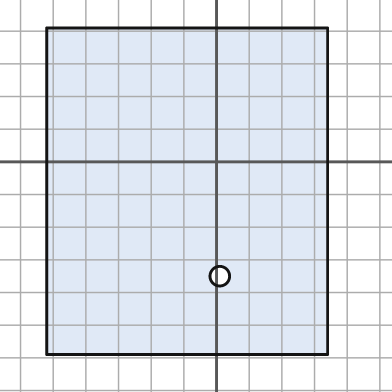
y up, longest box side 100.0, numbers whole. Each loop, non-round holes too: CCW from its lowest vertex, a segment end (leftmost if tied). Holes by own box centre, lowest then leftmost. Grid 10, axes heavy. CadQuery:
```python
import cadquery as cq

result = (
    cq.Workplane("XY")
    .moveTo(-52.0, -59.0)
    .lineTo(34.0, -59.0)
    .lineTo(34.0, 41.0)
    .lineTo(-52.0, 41.0)
    .close()
    .moveTo(1.0, -35.0)
    .circle(3.0)
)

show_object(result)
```